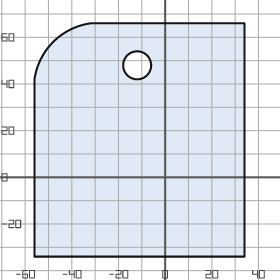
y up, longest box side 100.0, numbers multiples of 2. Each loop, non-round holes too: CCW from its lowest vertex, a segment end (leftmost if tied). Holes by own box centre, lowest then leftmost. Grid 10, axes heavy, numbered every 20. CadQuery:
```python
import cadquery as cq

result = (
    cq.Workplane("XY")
    .moveTo(-56.0, -34.0)
    .lineTo(34.0, -34.0)
    .lineTo(34.0, 66.0)
    .lineTo(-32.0, 66.0)
    .threePointArc((-48.0, 58.0), (-56.0, 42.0))
    .close()
    .moveTo(-12.0, 48.0)
    .circle(6.0)
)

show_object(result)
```